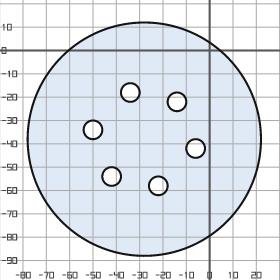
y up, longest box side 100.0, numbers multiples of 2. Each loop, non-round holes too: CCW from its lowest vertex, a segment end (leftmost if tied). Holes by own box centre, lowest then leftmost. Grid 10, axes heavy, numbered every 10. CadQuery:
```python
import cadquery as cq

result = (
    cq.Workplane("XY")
    .moveTo(-28.0, -38.0)
    .circle(50.0)
    .moveTo(-22.0, -58.0)
    .circle(4.0)
    .moveTo(-42.0, -54.0)
    .circle(4.0)
    .moveTo(-6.0, -42.0)
    .circle(4.0)
    .moveTo(-50.0, -34.0)
    .circle(4.0)
    .moveTo(-14.0, -22.0)
    .circle(4.0)
    .moveTo(-34.0, -18.0)
    .circle(4.0)
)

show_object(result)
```